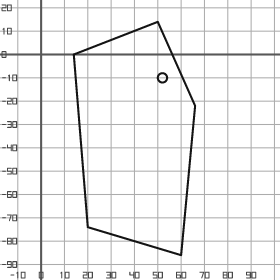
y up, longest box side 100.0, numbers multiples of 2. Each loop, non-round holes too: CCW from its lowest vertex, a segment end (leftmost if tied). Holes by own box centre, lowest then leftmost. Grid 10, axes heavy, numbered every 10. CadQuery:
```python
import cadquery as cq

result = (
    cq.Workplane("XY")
    .moveTo(60.0, -86.0)
    .lineTo(66.0, -22.0)
    .lineTo(50.0, 14.0)
    .lineTo(14.0, 0.0)
    .lineTo(20.0, -74.0)
    .close()
    .moveTo(52.0, -10.0)
    .circle(2.0)
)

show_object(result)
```